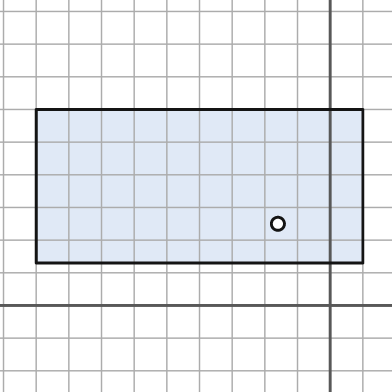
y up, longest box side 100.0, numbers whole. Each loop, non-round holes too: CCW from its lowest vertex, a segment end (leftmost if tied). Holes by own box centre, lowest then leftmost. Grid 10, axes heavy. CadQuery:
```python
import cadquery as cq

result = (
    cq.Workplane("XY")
    .moveTo(-90.0, 13.0)
    .lineTo(10.0, 13.0)
    .lineTo(10.0, 60.0)
    .lineTo(-90.0, 60.0)
    .close()
    .moveTo(-16.0, 25.0)
    .circle(2.0)
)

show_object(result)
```